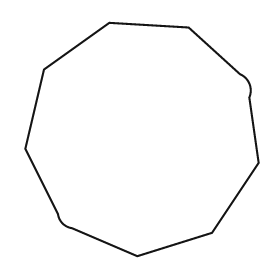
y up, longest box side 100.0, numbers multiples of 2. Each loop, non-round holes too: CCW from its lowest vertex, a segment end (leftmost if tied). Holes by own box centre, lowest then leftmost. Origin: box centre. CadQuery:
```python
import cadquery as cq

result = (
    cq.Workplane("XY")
    .moveTo(-2.0, -50.0)
    .lineTo(30.0, -40.0)
    .lineTo(50.0, -10.0)
    .lineTo(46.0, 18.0)
    .threePointArc((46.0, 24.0), (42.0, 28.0))
    .lineTo(20.0, 48.0)
    .lineTo(-14.0, 50.0)
    .lineTo(-42.0, 30.0)
    .lineTo(-50.0, -4.0)
    .lineTo(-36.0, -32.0)
    .threePointArc((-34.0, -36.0), (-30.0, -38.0))
    .close()
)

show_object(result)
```